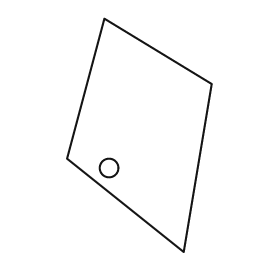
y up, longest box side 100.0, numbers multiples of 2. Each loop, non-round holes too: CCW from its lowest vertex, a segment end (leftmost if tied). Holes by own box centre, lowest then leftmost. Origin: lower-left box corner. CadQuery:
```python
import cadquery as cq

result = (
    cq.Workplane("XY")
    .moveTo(50.0, 0.0)
    .lineTo(62.0, 72.0)
    .lineTo(16.0, 100.0)
    .lineTo(0.0, 40.0)
    .close()
    .moveTo(18.0, 36.0)
    .circle(4.0)
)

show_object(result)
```